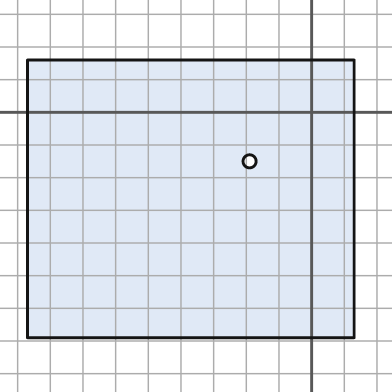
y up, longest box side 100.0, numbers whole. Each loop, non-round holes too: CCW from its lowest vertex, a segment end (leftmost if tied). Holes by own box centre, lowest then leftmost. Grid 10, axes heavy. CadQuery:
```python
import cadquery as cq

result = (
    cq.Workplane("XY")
    .moveTo(-87.0, -69.0)
    .lineTo(13.0, -69.0)
    .lineTo(13.0, 16.0)
    .lineTo(-87.0, 16.0)
    .close()
    .moveTo(-19.0, -15.0)
    .circle(2.0)
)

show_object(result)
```